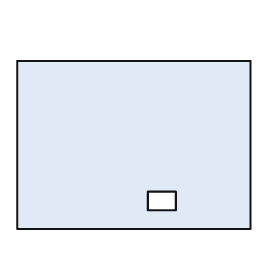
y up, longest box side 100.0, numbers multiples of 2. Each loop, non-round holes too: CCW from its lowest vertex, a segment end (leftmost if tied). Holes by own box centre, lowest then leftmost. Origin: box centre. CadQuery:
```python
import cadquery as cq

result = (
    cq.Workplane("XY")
    .moveTo(-50.0, -36.0)
    .lineTo(50.0, -36.0)
    .lineTo(50.0, 36.0)
    .lineTo(-50.0, 36.0)
    .close()
    .moveTo(6.0, -28.0)
    .lineTo(18.0, -28.0)
    .lineTo(18.0, -20.0)
    .lineTo(6.0, -20.0)
    .close()
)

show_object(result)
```